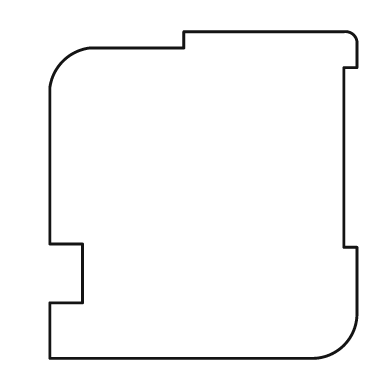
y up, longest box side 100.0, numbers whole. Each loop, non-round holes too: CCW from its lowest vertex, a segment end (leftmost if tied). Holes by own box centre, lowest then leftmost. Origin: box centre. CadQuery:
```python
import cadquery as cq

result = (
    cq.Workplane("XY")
    .moveTo(-47.0, -50.0)
    .lineTo(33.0, -50.0)
    .threePointArc((43.0, -46.0), (47.0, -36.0))
    .lineTo(47.0, -16.0)
    .lineTo(43.0, -16.0)
    .lineTo(43.0, 39.0)
    .lineTo(47.0, 39.0)
    .lineTo(47.0, 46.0)
    .threePointArc((46.0, 49.0), (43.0, 50.0))
    .lineTo(-6.0, 50.0)
    .lineTo(-6.0, 45.0)
    .lineTo(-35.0, 45.0)
    .threePointArc((-43.0, 41.0), (-47.0, 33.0))
    .lineTo(-47.0, -15.0)
    .lineTo(-37.0, -15.0)
    .lineTo(-37.0, -33.0)
    .lineTo(-47.0, -33.0)
    .close()
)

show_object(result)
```